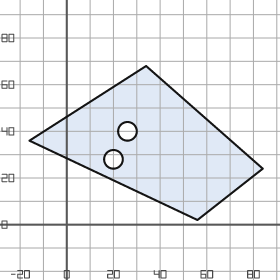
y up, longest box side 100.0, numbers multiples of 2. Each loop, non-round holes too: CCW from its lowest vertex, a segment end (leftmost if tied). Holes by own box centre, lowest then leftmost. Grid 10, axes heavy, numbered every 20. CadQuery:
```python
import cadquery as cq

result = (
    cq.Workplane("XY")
    .moveTo(56.0, 2.0)
    .lineTo(84.0, 24.0)
    .lineTo(34.0, 68.0)
    .lineTo(-16.0, 36.0)
    .close()
    .moveTo(20.0, 28.0)
    .circle(4.0)
    .moveTo(26.0, 40.0)
    .circle(4.0)
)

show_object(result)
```